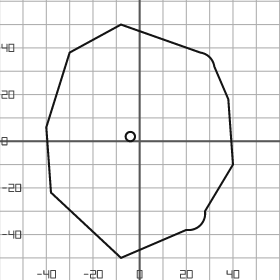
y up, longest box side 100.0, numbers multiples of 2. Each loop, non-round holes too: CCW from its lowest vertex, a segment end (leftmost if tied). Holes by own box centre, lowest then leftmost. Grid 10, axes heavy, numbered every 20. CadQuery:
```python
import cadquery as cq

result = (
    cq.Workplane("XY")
    .moveTo(-8.0, -50.0)
    .lineTo(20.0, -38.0)
    .threePointArc((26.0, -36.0), (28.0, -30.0))
    .lineTo(40.0, -10.0)
    .lineTo(38.0, 18.0)
    .lineTo(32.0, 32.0)
    .threePointArc((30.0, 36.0), (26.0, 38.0))
    .lineTo(-8.0, 50.0)
    .lineTo(-30.0, 38.0)
    .lineTo(-40.0, 6.0)
    .lineTo(-38.0, -22.0)
    .close()
    .moveTo(-4.0, 2.0)
    .circle(2.0)
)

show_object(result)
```